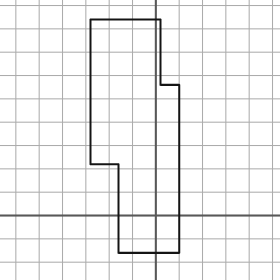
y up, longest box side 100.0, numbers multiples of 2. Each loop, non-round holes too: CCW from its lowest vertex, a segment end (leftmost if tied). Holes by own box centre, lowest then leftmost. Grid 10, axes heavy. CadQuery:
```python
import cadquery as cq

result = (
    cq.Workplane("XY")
    .moveTo(-16.0, -16.0)
    .lineTo(10.0, -16.0)
    .lineTo(10.0, 56.0)
    .lineTo(2.0, 56.0)
    .lineTo(2.0, 84.0)
    .lineTo(-28.0, 84.0)
    .lineTo(-28.0, 22.0)
    .lineTo(-16.0, 22.0)
    .close()
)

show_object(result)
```